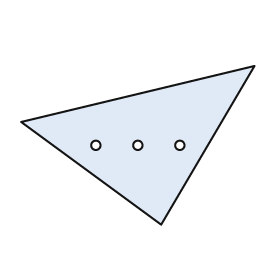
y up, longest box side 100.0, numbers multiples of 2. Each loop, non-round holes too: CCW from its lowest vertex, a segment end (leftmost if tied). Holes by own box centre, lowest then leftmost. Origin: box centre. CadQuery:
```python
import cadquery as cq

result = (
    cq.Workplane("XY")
    .moveTo(10.0, -34.0)
    .lineTo(50.0, 34.0)
    .lineTo(-50.0, 10.0)
    .close()
    .moveTo(-18.0, 0.0)
    .circle(2.0)
    .moveTo(0.0, 0.0)
    .circle(2.0)
    .moveTo(18.0, 0.0)
    .circle(2.0)
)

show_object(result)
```